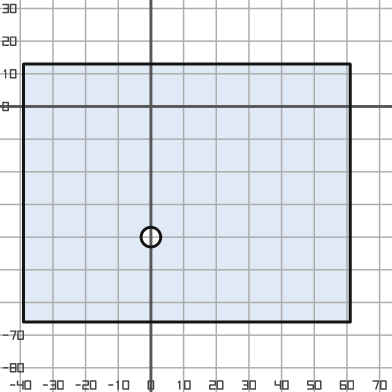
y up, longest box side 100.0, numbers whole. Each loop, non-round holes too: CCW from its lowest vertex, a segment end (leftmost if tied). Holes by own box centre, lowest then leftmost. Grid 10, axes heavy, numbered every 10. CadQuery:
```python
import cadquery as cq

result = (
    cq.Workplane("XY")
    .moveTo(-39.0, -66.0)
    .lineTo(61.0, -66.0)
    .lineTo(61.0, 13.0)
    .lineTo(-39.0, 13.0)
    .close()
    .moveTo(0.0, -40.0)
    .circle(3.0)
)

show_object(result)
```